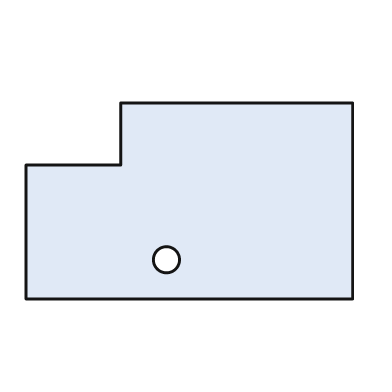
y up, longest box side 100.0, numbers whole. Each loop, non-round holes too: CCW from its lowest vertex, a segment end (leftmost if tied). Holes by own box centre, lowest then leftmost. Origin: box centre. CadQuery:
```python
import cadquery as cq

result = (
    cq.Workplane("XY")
    .moveTo(-50.0, -30.0)
    .lineTo(50.0, -30.0)
    .lineTo(50.0, 30.0)
    .lineTo(-21.0, 30.0)
    .lineTo(-21.0, 11.0)
    .lineTo(-50.0, 11.0)
    .close()
    .moveTo(-7.0, -18.0)
    .circle(4.0)
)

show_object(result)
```